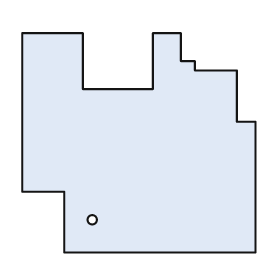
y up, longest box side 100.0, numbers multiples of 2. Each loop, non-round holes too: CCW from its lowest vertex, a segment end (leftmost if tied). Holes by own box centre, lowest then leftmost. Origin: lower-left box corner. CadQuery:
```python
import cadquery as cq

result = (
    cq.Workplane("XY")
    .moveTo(18.0, 0.0)
    .lineTo(100.0, 0.0)
    .lineTo(100.0, 56.0)
    .lineTo(92.0, 56.0)
    .lineTo(92.0, 78.0)
    .lineTo(74.0, 78.0)
    .lineTo(74.0, 82.0)
    .lineTo(68.0, 82.0)
    .lineTo(68.0, 94.0)
    .lineTo(56.0, 94.0)
    .lineTo(56.0, 70.0)
    .lineTo(26.0, 70.0)
    .lineTo(26.0, 94.0)
    .lineTo(0.0, 94.0)
    .lineTo(0.0, 26.0)
    .lineTo(18.0, 26.0)
    .close()
    .moveTo(30.0, 14.0)
    .circle(2.0)
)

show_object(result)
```